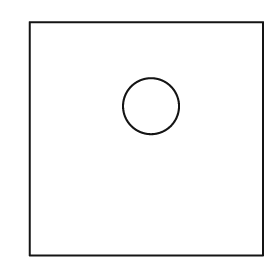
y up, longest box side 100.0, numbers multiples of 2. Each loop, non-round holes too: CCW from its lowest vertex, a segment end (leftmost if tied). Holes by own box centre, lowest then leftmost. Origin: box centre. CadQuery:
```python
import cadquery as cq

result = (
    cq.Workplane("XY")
    .moveTo(-50.0, -50.0)
    .lineTo(50.0, -50.0)
    .lineTo(50.0, 50.0)
    .lineTo(-50.0, 50.0)
    .close()
    .moveTo(2.0, 14.0)
    .circle(12.0)
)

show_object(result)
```